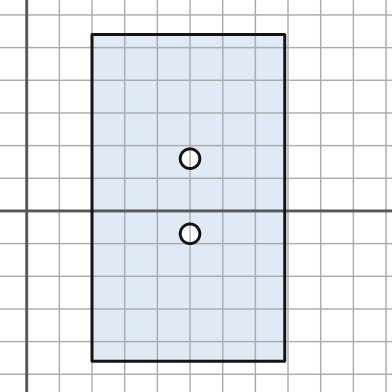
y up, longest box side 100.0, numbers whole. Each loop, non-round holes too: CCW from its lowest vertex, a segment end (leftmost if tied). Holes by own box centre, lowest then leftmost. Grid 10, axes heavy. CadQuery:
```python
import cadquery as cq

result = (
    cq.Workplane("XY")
    .moveTo(20.0, -46.0)
    .lineTo(79.0, -46.0)
    .lineTo(79.0, 54.0)
    .lineTo(20.0, 54.0)
    .close()
    .moveTo(50.0, -7.0)
    .circle(3.0)
    .moveTo(50.0, 16.0)
    .circle(3.0)
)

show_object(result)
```